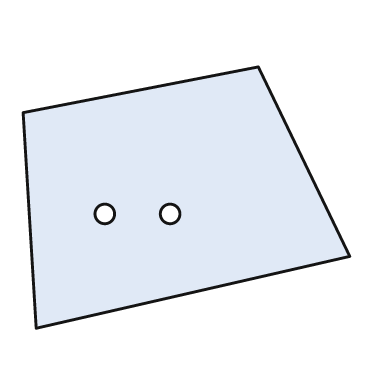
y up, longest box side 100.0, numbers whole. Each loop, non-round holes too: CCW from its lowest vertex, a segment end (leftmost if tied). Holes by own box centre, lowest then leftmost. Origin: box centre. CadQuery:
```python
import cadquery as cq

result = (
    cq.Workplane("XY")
    .moveTo(-46.0, -40.0)
    .lineTo(50.0, -18.0)
    .lineTo(22.0, 40.0)
    .lineTo(-50.0, 26.0)
    .close()
    .moveTo(-25.0, -5.0)
    .circle(3.0)
    .moveTo(-5.0, -5.0)
    .circle(3.0)
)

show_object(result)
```